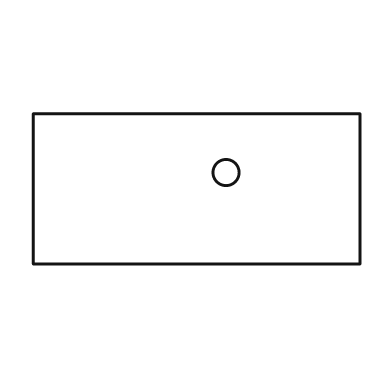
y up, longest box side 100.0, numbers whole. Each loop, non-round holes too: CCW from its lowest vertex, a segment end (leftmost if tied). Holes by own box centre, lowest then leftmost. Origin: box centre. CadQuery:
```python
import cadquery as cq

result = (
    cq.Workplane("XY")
    .moveTo(-50.0, -23.0)
    .lineTo(50.0, -23.0)
    .lineTo(50.0, 23.0)
    .lineTo(-50.0, 23.0)
    .close()
    .moveTo(9.0, 5.0)
    .circle(4.0)
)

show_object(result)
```